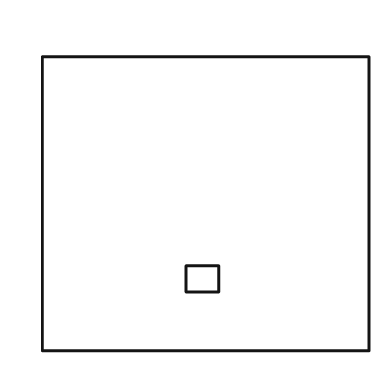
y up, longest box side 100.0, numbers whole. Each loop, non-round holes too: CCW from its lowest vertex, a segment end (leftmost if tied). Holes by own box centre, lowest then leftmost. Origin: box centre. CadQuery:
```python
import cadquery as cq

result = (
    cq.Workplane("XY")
    .moveTo(-50.0, -45.0)
    .lineTo(50.0, -45.0)
    .lineTo(50.0, 45.0)
    .lineTo(-50.0, 45.0)
    .close()
    .moveTo(-6.0, -27.0)
    .lineTo(4.0, -27.0)
    .lineTo(4.0, -19.0)
    .lineTo(-6.0, -19.0)
    .close()
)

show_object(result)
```